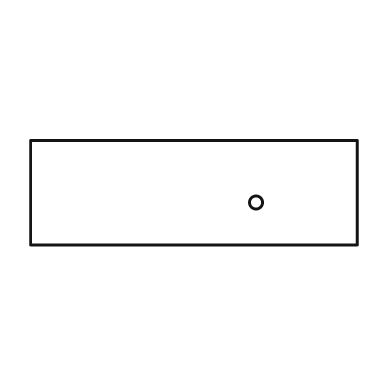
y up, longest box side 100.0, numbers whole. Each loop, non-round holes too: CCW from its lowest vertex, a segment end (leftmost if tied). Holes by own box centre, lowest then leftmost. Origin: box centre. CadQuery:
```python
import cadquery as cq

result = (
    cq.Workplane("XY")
    .moveTo(-50.0, -16.0)
    .lineTo(50.0, -16.0)
    .lineTo(50.0, 16.0)
    .lineTo(-50.0, 16.0)
    .close()
    .moveTo(19.0, -3.0)
    .circle(2.0)
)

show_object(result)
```